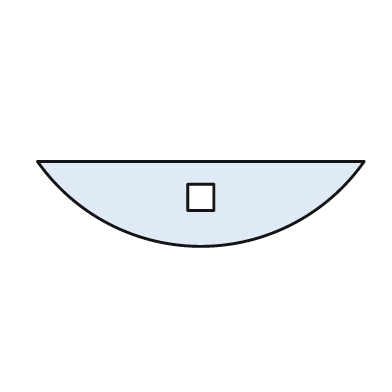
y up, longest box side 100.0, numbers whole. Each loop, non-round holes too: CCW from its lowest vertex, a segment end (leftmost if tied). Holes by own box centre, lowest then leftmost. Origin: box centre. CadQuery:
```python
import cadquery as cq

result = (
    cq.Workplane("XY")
    .moveTo(-50.0, 13.0)
    .threePointArc((0.0, -13.0), (50.0, 13.0))
    .close()
    .moveTo(-4.0, -2.0)
    .lineTo(4.0, -2.0)
    .lineTo(4.0, 6.0)
    .lineTo(-4.0, 6.0)
    .close()
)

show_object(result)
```